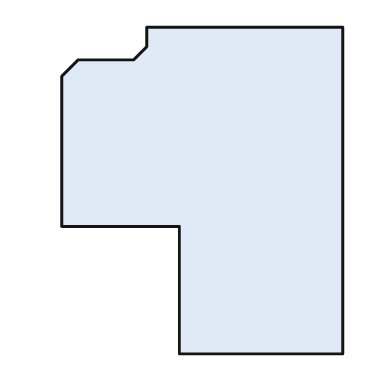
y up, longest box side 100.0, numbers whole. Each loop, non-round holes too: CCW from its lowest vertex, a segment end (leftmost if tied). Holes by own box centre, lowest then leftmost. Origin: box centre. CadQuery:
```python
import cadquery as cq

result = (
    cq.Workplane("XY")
    .moveTo(-7.0, -50.0)
    .lineTo(43.0, -50.0)
    .lineTo(43.0, 50.0)
    .lineTo(-17.0, 50.0)
    .lineTo(-17.0, 44.0)
    .lineTo(-21.0, 40.0)
    .lineTo(-38.0, 40.0)
    .lineTo(-43.0, 35.0)
    .lineTo(-43.0, -11.0)
    .lineTo(-7.0, -11.0)
    .close()
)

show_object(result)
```